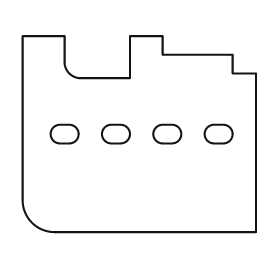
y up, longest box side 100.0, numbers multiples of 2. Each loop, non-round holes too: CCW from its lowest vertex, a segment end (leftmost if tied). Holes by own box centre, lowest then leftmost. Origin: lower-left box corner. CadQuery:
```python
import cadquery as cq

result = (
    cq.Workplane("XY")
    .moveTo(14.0, 0.0)
    .lineTo(100.0, 0.0)
    .lineTo(100.0, 68.0)
    .lineTo(90.0, 68.0)
    .lineTo(90.0, 76.0)
    .lineTo(60.0, 76.0)
    .lineTo(60.0, 84.0)
    .lineTo(46.0, 84.0)
    .lineTo(46.0, 66.0)
    .lineTo(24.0, 66.0)
    .threePointArc((20.0, 68.0), (18.0, 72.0))
    .lineTo(18.0, 84.0)
    .lineTo(0.0, 84.0)
    .lineTo(0.0, 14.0)
    .threePointArc((4.0, 4.0), (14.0, 0.0))
    .close()
    .moveTo(16.0, 38.0)
    .lineTo(20.0, 38.0)
    .threePointArc((24.0, 42.0), (20.0, 46.0))
    .lineTo(16.0, 46.0)
    .threePointArc((12.0, 42.0), (16.0, 38.0))
    .close()
    .moveTo(38.0, 38.0)
    .lineTo(42.0, 38.0)
    .threePointArc((46.0, 42.0), (42.0, 46.0))
    .lineTo(38.0, 46.0)
    .threePointArc((34.0, 42.0), (38.0, 38.0))
    .close()
    .moveTo(60.0, 38.0)
    .lineTo(64.0, 38.0)
    .threePointArc((68.0, 42.0), (64.0, 46.0))
    .lineTo(60.0, 46.0)
    .threePointArc((56.0, 42.0), (60.0, 38.0))
    .close()
    .moveTo(82.0, 38.0)
    .lineTo(86.0, 38.0)
    .threePointArc((90.0, 42.0), (86.0, 46.0))
    .lineTo(82.0, 46.0)
    .threePointArc((78.0, 42.0), (82.0, 38.0))
    .close()
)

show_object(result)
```